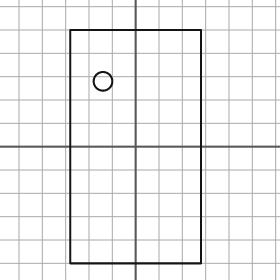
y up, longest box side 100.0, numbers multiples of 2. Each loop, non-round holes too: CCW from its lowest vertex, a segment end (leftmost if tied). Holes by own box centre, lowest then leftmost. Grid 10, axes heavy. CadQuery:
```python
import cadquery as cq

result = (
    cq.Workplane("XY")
    .moveTo(-28.0, -50.0)
    .lineTo(28.0, -50.0)
    .lineTo(28.0, 50.0)
    .lineTo(-28.0, 50.0)
    .close()
    .moveTo(-14.0, 28.0)
    .circle(4.0)
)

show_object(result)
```